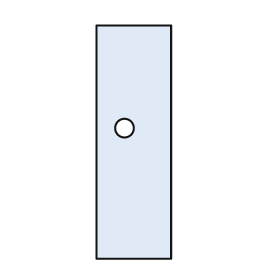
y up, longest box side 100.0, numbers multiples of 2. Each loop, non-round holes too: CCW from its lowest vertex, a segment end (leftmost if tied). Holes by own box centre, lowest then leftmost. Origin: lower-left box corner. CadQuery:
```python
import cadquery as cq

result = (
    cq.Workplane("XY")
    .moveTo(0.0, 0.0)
    .lineTo(32.0, 0.0)
    .lineTo(32.0, 100.0)
    .lineTo(0.0, 100.0)
    .close()
    .moveTo(12.0, 56.0)
    .circle(4.0)
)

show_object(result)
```